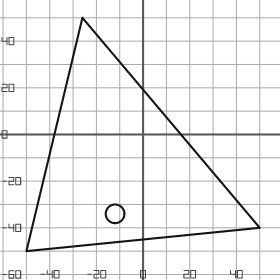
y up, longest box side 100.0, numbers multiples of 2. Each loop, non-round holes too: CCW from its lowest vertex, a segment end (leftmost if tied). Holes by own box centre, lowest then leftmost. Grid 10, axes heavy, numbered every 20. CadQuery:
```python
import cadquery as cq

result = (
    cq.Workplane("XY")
    .moveTo(-50.0, -50.0)
    .lineTo(50.0, -40.0)
    .lineTo(-26.0, 50.0)
    .close()
    .moveTo(-12.0, -34.0)
    .circle(4.0)
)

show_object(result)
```